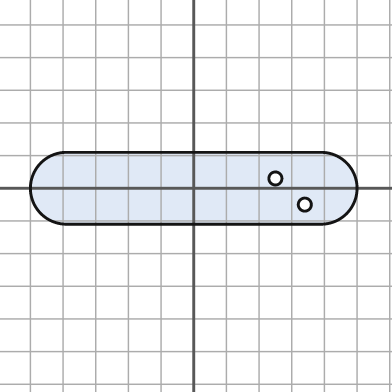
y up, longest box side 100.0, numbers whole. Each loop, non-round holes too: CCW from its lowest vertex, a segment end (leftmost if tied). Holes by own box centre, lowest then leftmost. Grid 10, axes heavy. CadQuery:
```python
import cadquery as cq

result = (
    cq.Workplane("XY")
    .moveTo(-39.0, -11.0)
    .lineTo(39.0, -11.0)
    .threePointArc((50.0, 0.0), (39.0, 11.0))
    .lineTo(-39.0, 11.0)
    .threePointArc((-50.0, 0.0), (-39.0, -11.0))
    .close()
    .moveTo(34.0, -5.0)
    .circle(2.0)
    .moveTo(25.0, 3.0)
    .circle(2.0)
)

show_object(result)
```